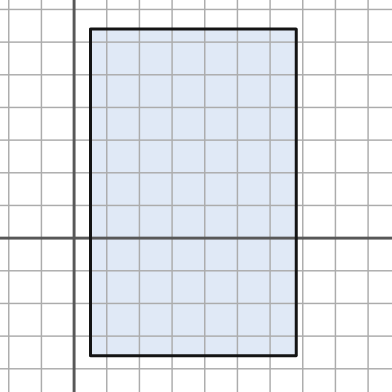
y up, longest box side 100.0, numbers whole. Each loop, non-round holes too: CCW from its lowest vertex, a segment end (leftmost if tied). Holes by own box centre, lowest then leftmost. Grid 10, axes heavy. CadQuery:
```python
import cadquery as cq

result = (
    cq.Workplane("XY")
    .moveTo(5.0, -36.0)
    .lineTo(68.0, -36.0)
    .lineTo(68.0, 64.0)
    .lineTo(5.0, 64.0)
    .close()
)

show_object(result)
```